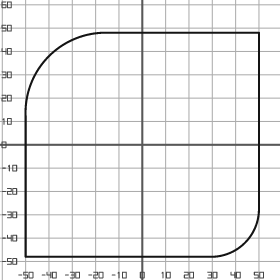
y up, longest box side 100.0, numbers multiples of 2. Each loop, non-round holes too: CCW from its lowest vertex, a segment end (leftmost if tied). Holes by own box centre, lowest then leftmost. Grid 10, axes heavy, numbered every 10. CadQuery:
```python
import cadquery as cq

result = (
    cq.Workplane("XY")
    .moveTo(-50.0, -48.0)
    .lineTo(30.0, -48.0)
    .threePointArc((44.0, -42.0), (50.0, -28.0))
    .lineTo(50.0, 48.0)
    .lineTo(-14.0, 48.0)
    .threePointArc((-40.0, 38.0), (-50.0, 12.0))
    .close()
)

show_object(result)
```